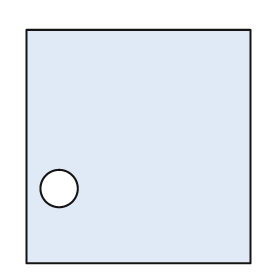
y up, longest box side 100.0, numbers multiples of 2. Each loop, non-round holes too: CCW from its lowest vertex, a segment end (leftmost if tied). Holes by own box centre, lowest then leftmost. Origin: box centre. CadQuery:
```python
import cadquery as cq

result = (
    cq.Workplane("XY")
    .moveTo(-48.0, -50.0)
    .lineTo(48.0, -50.0)
    .lineTo(48.0, 50.0)
    .lineTo(-48.0, 50.0)
    .close()
    .moveTo(-34.0, -18.0)
    .circle(8.0)
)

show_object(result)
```